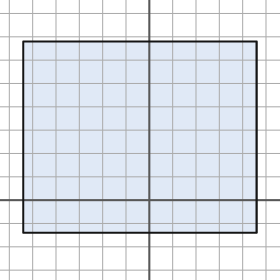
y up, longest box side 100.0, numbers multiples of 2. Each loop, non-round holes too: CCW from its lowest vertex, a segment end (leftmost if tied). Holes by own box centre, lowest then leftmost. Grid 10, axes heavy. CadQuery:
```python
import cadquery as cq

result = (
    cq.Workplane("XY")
    .moveTo(-54.0, -14.0)
    .lineTo(46.0, -14.0)
    .lineTo(46.0, 68.0)
    .lineTo(-54.0, 68.0)
    .close()
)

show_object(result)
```